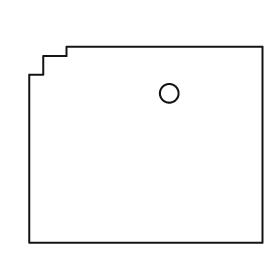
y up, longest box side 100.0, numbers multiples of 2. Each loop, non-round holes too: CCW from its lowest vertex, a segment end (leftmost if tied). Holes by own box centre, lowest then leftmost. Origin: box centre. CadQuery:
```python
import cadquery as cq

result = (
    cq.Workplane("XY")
    .moveTo(-50.0, -42.0)
    .lineTo(50.0, -42.0)
    .lineTo(50.0, 42.0)
    .lineTo(-34.0, 42.0)
    .lineTo(-34.0, 38.0)
    .lineTo(-44.0, 38.0)
    .lineTo(-44.0, 30.0)
    .lineTo(-50.0, 30.0)
    .close()
    .moveTo(10.0, 22.0)
    .circle(4.0)
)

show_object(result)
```